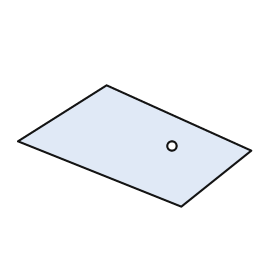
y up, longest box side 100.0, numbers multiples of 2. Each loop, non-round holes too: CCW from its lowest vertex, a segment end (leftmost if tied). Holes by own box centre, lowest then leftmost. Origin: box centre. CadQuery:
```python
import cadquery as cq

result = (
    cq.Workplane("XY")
    .moveTo(20.0, -26.0)
    .lineTo(50.0, -2.0)
    .lineTo(-12.0, 26.0)
    .lineTo(-50.0, 2.0)
    .close()
    .moveTo(16.0, 0.0)
    .circle(2.0)
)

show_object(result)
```